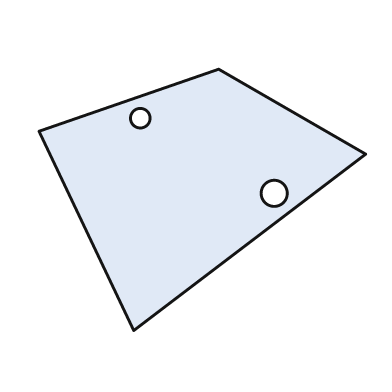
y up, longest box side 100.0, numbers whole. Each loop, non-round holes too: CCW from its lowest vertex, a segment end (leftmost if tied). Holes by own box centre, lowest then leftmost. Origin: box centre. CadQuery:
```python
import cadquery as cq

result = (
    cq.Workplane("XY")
    .moveTo(-21.0, -40.0)
    .lineTo(50.0, 14.0)
    .lineTo(5.0, 40.0)
    .lineTo(-50.0, 21.0)
    .close()
    .moveTo(22.0, 2.0)
    .circle(4.0)
    .moveTo(-19.0, 25.0)
    .circle(3.0)
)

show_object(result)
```